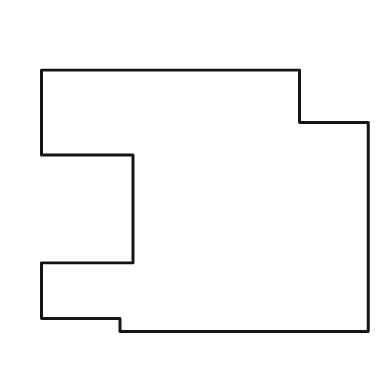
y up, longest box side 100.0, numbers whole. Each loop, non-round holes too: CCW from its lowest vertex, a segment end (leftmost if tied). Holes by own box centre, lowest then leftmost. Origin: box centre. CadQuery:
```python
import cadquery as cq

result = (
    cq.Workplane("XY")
    .moveTo(-26.0, -40.0)
    .lineTo(50.0, -40.0)
    .lineTo(50.0, 24.0)
    .lineTo(29.0, 24.0)
    .lineTo(29.0, 40.0)
    .lineTo(-50.0, 40.0)
    .lineTo(-50.0, 14.0)
    .lineTo(-22.0, 14.0)
    .lineTo(-22.0, -19.0)
    .lineTo(-50.0, -19.0)
    .lineTo(-50.0, -36.0)
    .lineTo(-26.0, -36.0)
    .close()
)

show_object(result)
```